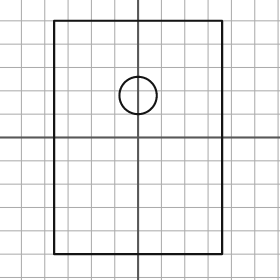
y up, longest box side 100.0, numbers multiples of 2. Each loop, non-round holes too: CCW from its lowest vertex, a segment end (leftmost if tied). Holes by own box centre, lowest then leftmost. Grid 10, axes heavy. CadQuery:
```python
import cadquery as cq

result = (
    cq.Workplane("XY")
    .moveTo(-36.0, -50.0)
    .lineTo(36.0, -50.0)
    .lineTo(36.0, 50.0)
    .lineTo(-36.0, 50.0)
    .close()
    .moveTo(0.0, 18.0)
    .circle(8.0)
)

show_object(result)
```